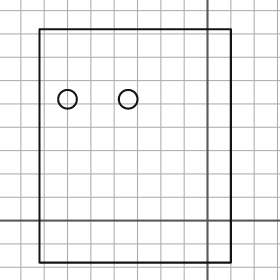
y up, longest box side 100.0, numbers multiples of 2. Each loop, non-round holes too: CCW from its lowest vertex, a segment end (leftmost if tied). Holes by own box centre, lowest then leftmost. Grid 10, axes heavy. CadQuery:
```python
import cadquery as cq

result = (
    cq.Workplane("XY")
    .moveTo(-72.0, -18.0)
    .lineTo(10.0, -18.0)
    .lineTo(10.0, 82.0)
    .lineTo(-72.0, 82.0)
    .close()
    .moveTo(-60.0, 52.0)
    .circle(4.0)
    .moveTo(-34.0, 52.0)
    .circle(4.0)
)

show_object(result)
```